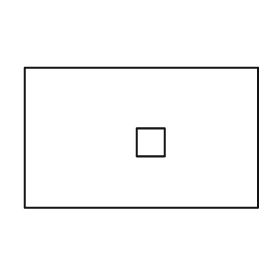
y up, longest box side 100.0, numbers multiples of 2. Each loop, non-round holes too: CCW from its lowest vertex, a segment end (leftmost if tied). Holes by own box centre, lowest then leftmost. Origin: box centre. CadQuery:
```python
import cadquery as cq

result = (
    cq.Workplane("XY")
    .moveTo(-50.0, -30.0)
    .lineTo(50.0, -30.0)
    .lineTo(50.0, 30.0)
    .lineTo(-50.0, 30.0)
    .close()
    .moveTo(-2.0, -8.0)
    .lineTo(10.0, -8.0)
    .lineTo(10.0, 4.0)
    .lineTo(-2.0, 4.0)
    .close()
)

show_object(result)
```